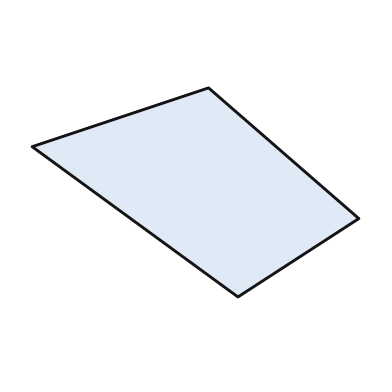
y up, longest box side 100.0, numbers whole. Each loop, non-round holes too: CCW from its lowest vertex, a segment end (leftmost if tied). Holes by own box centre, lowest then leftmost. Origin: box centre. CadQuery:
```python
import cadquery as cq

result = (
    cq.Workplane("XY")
    .moveTo(13.0, -32.0)
    .lineTo(50.0, -8.0)
    .lineTo(4.0, 32.0)
    .lineTo(-50.0, 14.0)
    .close()
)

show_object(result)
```